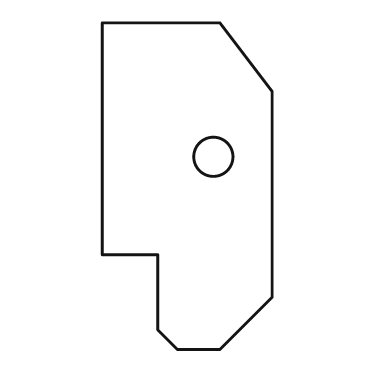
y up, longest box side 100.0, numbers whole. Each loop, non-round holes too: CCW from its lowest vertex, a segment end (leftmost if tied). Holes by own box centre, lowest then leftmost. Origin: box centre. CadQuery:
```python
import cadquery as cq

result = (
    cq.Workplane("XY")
    .moveTo(-3.0, -50.0)
    .lineTo(10.0, -50.0)
    .lineTo(26.0, -34.0)
    .lineTo(26.0, 29.0)
    .lineTo(10.0, 50.0)
    .lineTo(-26.0, 50.0)
    .lineTo(-26.0, -21.0)
    .lineTo(-9.0, -21.0)
    .lineTo(-9.0, -44.0)
    .close()
    .moveTo(8.0, 9.0)
    .circle(6.0)
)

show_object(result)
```